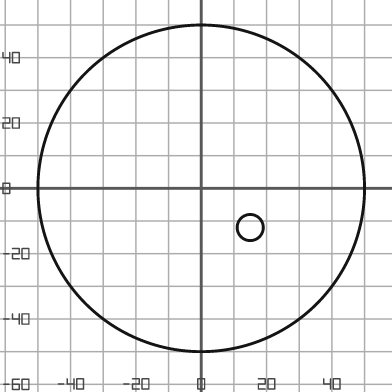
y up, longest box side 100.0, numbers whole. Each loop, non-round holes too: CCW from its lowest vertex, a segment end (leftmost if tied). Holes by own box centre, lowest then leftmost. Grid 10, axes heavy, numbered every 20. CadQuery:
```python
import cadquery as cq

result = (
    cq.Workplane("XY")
    .moveTo(0.0, 0.0)
    .circle(50.0)
    .moveTo(15.0, -12.0)
    .circle(4.0)
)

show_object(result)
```